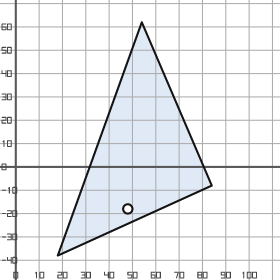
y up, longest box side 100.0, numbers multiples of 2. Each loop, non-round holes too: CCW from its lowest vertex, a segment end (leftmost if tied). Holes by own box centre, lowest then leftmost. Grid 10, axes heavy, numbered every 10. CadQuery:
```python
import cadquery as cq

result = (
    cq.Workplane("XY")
    .moveTo(18.0, -38.0)
    .lineTo(84.0, -8.0)
    .lineTo(54.0, 62.0)
    .close()
    .moveTo(48.0, -18.0)
    .circle(2.0)
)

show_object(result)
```